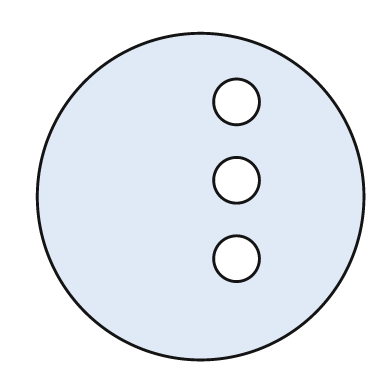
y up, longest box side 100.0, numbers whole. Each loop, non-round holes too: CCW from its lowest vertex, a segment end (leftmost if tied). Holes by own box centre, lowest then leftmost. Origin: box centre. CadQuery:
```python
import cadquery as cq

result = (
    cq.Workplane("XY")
    .moveTo(0.0, 0.0)
    .circle(50.0)
    .moveTo(11.0, -19.0)
    .circle(7.0)
    .moveTo(11.0, 5.0)
    .circle(7.0)
    .moveTo(11.0, 29.0)
    .circle(7.0)
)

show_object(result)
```